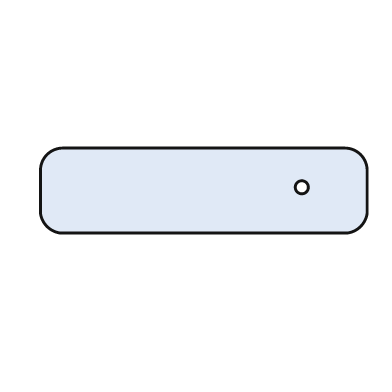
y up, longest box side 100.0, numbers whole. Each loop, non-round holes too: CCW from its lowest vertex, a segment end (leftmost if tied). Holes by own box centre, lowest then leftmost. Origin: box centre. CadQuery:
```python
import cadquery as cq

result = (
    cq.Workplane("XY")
    .moveTo(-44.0, -13.0)
    .lineTo(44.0, -13.0)
    .threePointArc((48.0, -11.0), (50.0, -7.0))
    .lineTo(50.0, 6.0)
    .threePointArc((48.0, 11.0), (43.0, 13.0))
    .lineTo(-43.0, 13.0)
    .threePointArc((-48.0, 11.0), (-50.0, 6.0))
    .lineTo(-50.0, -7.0)
    .threePointArc((-48.0, -11.0), (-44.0, -13.0))
    .close()
    .moveTo(30.0, 1.0)
    .circle(2.0)
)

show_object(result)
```